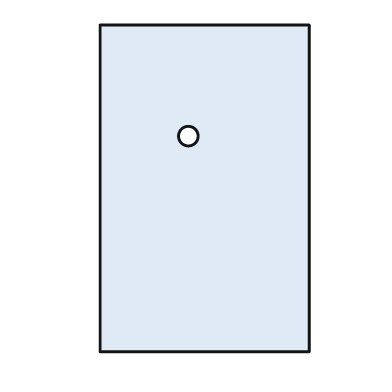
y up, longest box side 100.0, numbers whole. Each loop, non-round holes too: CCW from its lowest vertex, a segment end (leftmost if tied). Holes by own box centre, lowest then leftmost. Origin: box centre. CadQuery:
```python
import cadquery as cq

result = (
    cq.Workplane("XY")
    .moveTo(-32.0, -50.0)
    .lineTo(32.0, -50.0)
    .lineTo(32.0, 50.0)
    .lineTo(-32.0, 50.0)
    .close()
    .moveTo(-5.0, 16.0)
    .circle(3.0)
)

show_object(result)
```